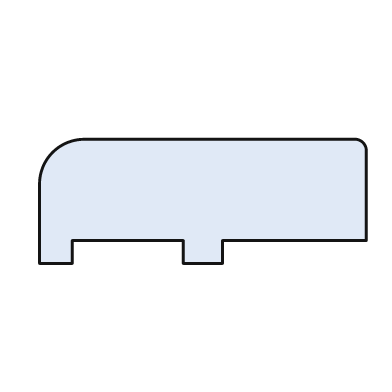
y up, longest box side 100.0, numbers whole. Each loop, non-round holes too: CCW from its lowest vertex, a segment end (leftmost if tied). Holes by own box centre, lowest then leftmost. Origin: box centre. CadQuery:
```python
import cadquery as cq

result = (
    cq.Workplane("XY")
    .moveTo(-50.0, -19.0)
    .lineTo(-40.0, -19.0)
    .lineTo(-40.0, -12.0)
    .lineTo(-6.0, -12.0)
    .lineTo(-6.0, -19.0)
    .lineTo(6.0, -19.0)
    .lineTo(6.0, -12.0)
    .lineTo(50.0, -12.0)
    .lineTo(50.0, 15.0)
    .threePointArc((49.0, 18.0), (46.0, 19.0))
    .lineTo(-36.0, 19.0)
    .threePointArc((-46.0, 15.0), (-50.0, 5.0))
    .close()
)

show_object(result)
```